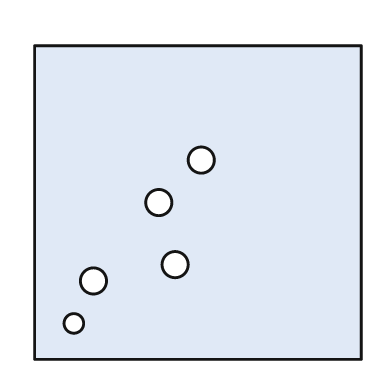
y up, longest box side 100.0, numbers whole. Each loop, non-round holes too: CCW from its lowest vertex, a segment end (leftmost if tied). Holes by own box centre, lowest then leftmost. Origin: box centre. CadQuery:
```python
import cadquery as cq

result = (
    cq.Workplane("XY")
    .moveTo(-50.0, -48.0)
    .lineTo(50.0, -48.0)
    .lineTo(50.0, 48.0)
    .lineTo(-50.0, 48.0)
    .close()
    .moveTo(-38.0, -37.0)
    .circle(3.0)
    .moveTo(-32.0, -24.0)
    .circle(4.0)
    .moveTo(-7.0, -19.0)
    .circle(4.0)
    .moveTo(-12.0, 0.0)
    .circle(4.0)
    .moveTo(1.0, 13.0)
    .circle(4.0)
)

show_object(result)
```